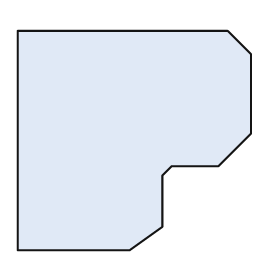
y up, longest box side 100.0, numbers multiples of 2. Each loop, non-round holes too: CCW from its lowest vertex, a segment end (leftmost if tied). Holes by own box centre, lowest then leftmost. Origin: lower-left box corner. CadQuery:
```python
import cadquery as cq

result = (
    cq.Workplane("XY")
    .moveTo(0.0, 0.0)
    .lineTo(48.0, 0.0)
    .lineTo(62.0, 10.0)
    .lineTo(62.0, 32.0)
    .lineTo(66.0, 36.0)
    .lineTo(86.0, 36.0)
    .lineTo(100.0, 50.0)
    .lineTo(100.0, 84.0)
    .lineTo(90.0, 94.0)
    .lineTo(0.0, 94.0)
    .close()
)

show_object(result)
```